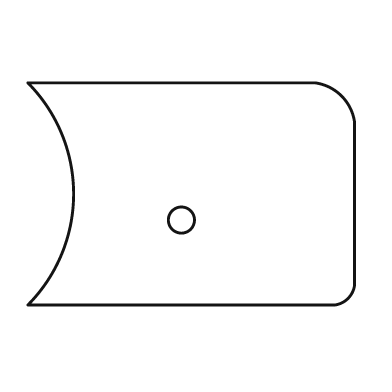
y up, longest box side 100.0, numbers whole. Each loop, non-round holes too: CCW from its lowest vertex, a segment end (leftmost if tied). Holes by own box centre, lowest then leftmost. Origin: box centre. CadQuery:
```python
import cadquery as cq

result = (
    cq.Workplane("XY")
    .moveTo(-50.0, -34.0)
    .lineTo(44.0, -34.0)
    .threePointArc((48.0, -32.0), (50.0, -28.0))
    .lineTo(50.0, 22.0)
    .threePointArc((46.0, 30.0), (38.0, 34.0))
    .lineTo(-50.0, 34.0)
    .threePointArc((-36.0, 0.0), (-50.0, -34.0))
    .close()
    .moveTo(-3.0, -8.0)
    .circle(4.0)
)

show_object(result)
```